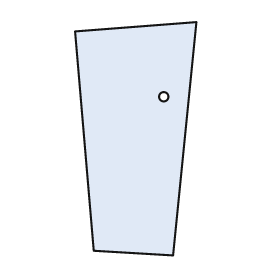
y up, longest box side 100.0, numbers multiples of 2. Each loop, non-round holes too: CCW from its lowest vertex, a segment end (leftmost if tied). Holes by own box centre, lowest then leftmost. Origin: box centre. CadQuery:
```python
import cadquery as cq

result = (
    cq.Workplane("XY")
    .moveTo(16.0, -50.0)
    .lineTo(26.0, 50.0)
    .lineTo(-26.0, 46.0)
    .lineTo(-18.0, -48.0)
    .close()
    .moveTo(12.0, 18.0)
    .circle(2.0)
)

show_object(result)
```